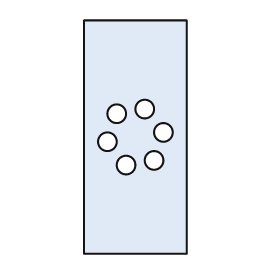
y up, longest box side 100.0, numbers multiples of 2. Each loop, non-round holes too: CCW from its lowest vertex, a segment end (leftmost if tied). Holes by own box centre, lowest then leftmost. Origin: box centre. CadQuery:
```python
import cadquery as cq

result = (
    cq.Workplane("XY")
    .moveTo(-22.0, -50.0)
    .lineTo(22.0, -50.0)
    .lineTo(22.0, 50.0)
    .lineTo(-22.0, 50.0)
    .close()
    .moveTo(-4.0, -12.0)
    .circle(4.0)
    .moveTo(8.0, -10.0)
    .circle(4.0)
    .moveTo(-12.0, -2.0)
    .circle(4.0)
    .moveTo(12.0, 2.0)
    .circle(4.0)
    .moveTo(-8.0, 10.0)
    .circle(4.0)
    .moveTo(4.0, 12.0)
    .circle(4.0)
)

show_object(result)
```